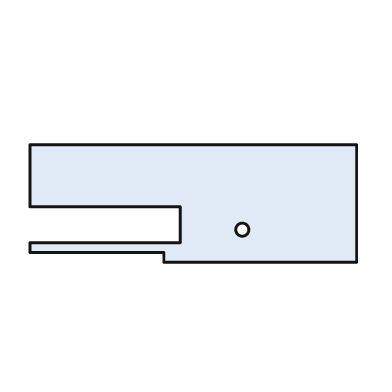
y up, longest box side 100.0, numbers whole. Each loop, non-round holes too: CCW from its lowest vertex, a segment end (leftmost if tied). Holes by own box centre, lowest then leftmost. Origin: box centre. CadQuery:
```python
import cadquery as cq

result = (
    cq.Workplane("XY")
    .moveTo(-9.0, -18.0)
    .lineTo(50.0, -18.0)
    .lineTo(50.0, 18.0)
    .lineTo(-50.0, 18.0)
    .lineTo(-50.0, -1.0)
    .lineTo(-4.0, -1.0)
    .lineTo(-4.0, -12.0)
    .lineTo(-50.0, -12.0)
    .lineTo(-50.0, -15.0)
    .lineTo(-9.0, -15.0)
    .close()
    .moveTo(15.0, -8.0)
    .circle(2.0)
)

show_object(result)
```